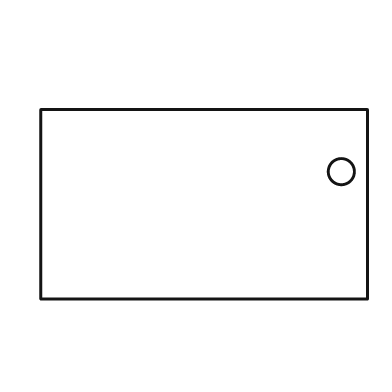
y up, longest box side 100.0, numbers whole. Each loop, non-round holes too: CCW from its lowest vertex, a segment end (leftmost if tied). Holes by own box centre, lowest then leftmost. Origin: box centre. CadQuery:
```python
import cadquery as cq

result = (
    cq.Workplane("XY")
    .moveTo(-50.0, -29.0)
    .lineTo(50.0, -29.0)
    .lineTo(50.0, 29.0)
    .lineTo(-50.0, 29.0)
    .close()
    .moveTo(42.0, 10.0)
    .circle(4.0)
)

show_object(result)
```